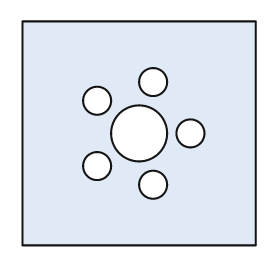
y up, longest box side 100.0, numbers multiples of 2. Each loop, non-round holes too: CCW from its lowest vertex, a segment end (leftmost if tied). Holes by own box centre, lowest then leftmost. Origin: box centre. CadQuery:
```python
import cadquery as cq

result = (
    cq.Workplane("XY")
    .moveTo(-50.0, -48.0)
    .lineTo(50.0, -48.0)
    .lineTo(50.0, 48.0)
    .lineTo(-50.0, 48.0)
    .close()
    .moveTo(6.0, -22.0)
    .circle(6.0)
    .moveTo(-18.0, -14.0)
    .circle(6.0)
    .moveTo(0.0, 0.0)
    .circle(12.0)
    .moveTo(22.0, 0.0)
    .circle(6.0)
    .moveTo(-18.0, 14.0)
    .circle(6.0)
    .moveTo(6.0, 22.0)
    .circle(6.0)
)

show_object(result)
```